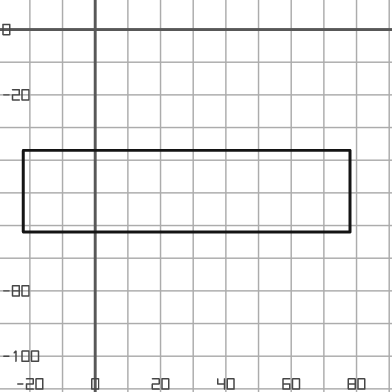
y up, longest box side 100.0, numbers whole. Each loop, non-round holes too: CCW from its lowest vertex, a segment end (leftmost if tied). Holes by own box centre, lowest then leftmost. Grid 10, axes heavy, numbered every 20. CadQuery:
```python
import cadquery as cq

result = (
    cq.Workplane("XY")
    .moveTo(-22.0, -62.0)
    .lineTo(78.0, -62.0)
    .lineTo(78.0, -37.0)
    .lineTo(-22.0, -37.0)
    .close()
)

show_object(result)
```